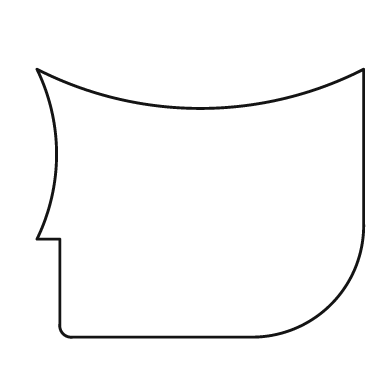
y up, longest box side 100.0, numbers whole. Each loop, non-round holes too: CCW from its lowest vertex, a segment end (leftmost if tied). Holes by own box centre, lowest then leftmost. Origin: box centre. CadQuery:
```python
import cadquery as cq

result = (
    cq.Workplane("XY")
    .moveTo(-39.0, -41.0)
    .lineTo(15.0, -41.0)
    .threePointArc((40.0, -31.0), (50.0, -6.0))
    .lineTo(50.0, 41.0)
    .threePointArc((0.0, 29.0), (-50.0, 41.0))
    .threePointArc((-44.0, 15.0), (-50.0, -11.0))
    .lineTo(-43.0, -11.0)
    .lineTo(-43.0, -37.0)
    .threePointArc((-42.0, -40.0), (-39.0, -41.0))
    .close()
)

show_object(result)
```